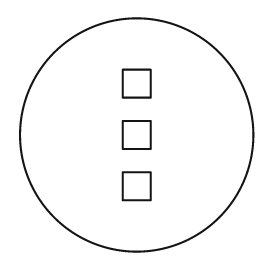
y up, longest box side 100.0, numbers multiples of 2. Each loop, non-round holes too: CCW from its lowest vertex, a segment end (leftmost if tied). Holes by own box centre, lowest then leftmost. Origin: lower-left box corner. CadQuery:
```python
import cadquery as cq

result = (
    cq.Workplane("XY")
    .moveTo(50.0, 50.0)
    .circle(50.0)
    .moveTo(44.0, 22.0)
    .lineTo(56.0, 22.0)
    .lineTo(56.0, 34.0)
    .lineTo(44.0, 34.0)
    .close()
    .moveTo(44.0, 44.0)
    .lineTo(56.0, 44.0)
    .lineTo(56.0, 56.0)
    .lineTo(44.0, 56.0)
    .close()
    .moveTo(44.0, 66.0)
    .lineTo(56.0, 66.0)
    .lineTo(56.0, 78.0)
    .lineTo(44.0, 78.0)
    .close()
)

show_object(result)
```